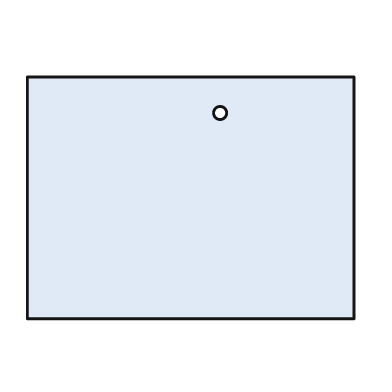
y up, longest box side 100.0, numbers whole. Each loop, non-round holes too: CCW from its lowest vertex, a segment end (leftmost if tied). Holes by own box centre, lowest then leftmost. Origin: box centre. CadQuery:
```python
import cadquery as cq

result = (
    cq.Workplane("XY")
    .moveTo(-50.0, -37.0)
    .lineTo(50.0, -37.0)
    .lineTo(50.0, 37.0)
    .lineTo(-50.0, 37.0)
    .close()
    .moveTo(9.0, 26.0)
    .circle(2.0)
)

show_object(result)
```